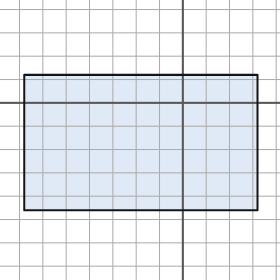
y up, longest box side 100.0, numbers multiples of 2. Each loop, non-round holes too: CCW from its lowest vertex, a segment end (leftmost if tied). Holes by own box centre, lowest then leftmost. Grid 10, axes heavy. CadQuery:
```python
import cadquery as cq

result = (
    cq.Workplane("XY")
    .moveTo(-68.0, -46.0)
    .lineTo(32.0, -46.0)
    .lineTo(32.0, 12.0)
    .lineTo(-68.0, 12.0)
    .close()
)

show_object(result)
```